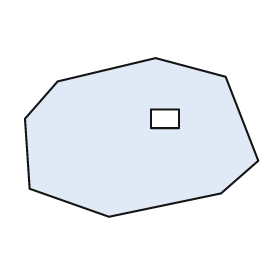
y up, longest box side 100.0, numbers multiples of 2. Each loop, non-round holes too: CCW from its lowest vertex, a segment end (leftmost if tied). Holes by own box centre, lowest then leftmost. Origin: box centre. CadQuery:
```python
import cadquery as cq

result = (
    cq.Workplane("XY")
    .moveTo(-14.0, -34.0)
    .lineTo(34.0, -24.0)
    .lineTo(50.0, -10.0)
    .lineTo(36.0, 26.0)
    .lineTo(6.0, 34.0)
    .lineTo(-36.0, 24.0)
    .lineTo(-50.0, 8.0)
    .lineTo(-48.0, -22.0)
    .close()
    .moveTo(4.0, 4.0)
    .lineTo(16.0, 4.0)
    .lineTo(16.0, 12.0)
    .lineTo(4.0, 12.0)
    .close()
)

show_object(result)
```